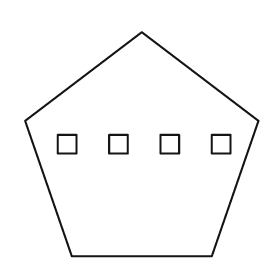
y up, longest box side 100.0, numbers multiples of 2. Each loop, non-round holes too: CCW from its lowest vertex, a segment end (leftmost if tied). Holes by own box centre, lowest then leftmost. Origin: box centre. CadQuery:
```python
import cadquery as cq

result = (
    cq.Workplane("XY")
    .moveTo(-30.0, -48.0)
    .lineTo(30.0, -48.0)
    .lineTo(50.0, 10.0)
    .lineTo(0.0, 48.0)
    .lineTo(-50.0, 10.0)
    .close()
    .moveTo(-36.0, -4.0)
    .lineTo(-28.0, -4.0)
    .lineTo(-28.0, 4.0)
    .lineTo(-36.0, 4.0)
    .close()
    .moveTo(-14.0, -4.0)
    .lineTo(-6.0, -4.0)
    .lineTo(-6.0, 4.0)
    .lineTo(-14.0, 4.0)
    .close()
    .moveTo(8.0, -4.0)
    .lineTo(16.0, -4.0)
    .lineTo(16.0, 4.0)
    .lineTo(8.0, 4.0)
    .close()
    .moveTo(30.0, -4.0)
    .lineTo(38.0, -4.0)
    .lineTo(38.0, 4.0)
    .lineTo(30.0, 4.0)
    .close()
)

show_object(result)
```